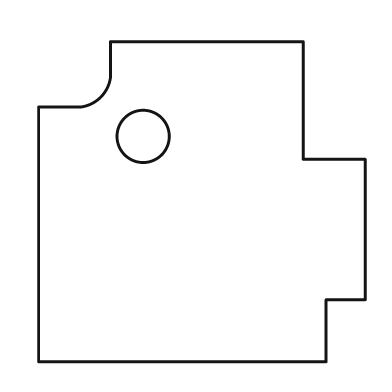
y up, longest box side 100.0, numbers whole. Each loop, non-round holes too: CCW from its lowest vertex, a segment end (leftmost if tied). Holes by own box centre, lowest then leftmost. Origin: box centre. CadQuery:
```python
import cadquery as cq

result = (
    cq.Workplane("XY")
    .moveTo(-50.0, -49.0)
    .lineTo(38.0, -49.0)
    .lineTo(38.0, -30.0)
    .lineTo(50.0, -30.0)
    .lineTo(50.0, 13.0)
    .lineTo(31.0, 13.0)
    .lineTo(31.0, 49.0)
    .lineTo(-28.0, 49.0)
    .lineTo(-28.0, 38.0)
    .threePointArc((-31.0, 32.0), (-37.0, 29.0))
    .lineTo(-50.0, 29.0)
    .close()
    .moveTo(-18.0, 20.0)
    .circle(8.0)
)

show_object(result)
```